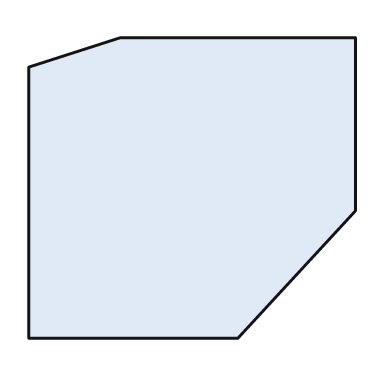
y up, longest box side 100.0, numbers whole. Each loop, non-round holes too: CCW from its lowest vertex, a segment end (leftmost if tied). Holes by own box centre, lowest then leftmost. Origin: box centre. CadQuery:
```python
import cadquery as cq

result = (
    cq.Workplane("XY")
    .moveTo(-50.0, -46.0)
    .lineTo(14.0, -46.0)
    .lineTo(50.0, -7.0)
    .lineTo(50.0, 46.0)
    .lineTo(-22.0, 46.0)
    .lineTo(-50.0, 37.0)
    .close()
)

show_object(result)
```